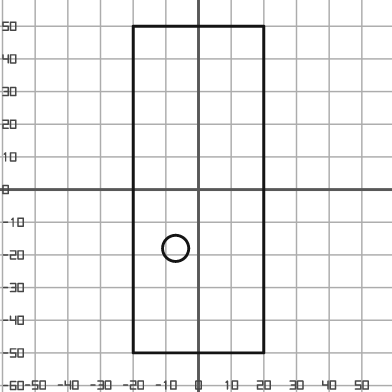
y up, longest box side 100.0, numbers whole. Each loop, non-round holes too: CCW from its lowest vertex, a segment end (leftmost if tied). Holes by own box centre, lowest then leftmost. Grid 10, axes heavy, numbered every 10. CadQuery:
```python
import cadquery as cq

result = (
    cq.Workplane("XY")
    .moveTo(-20.0, -50.0)
    .lineTo(20.0, -50.0)
    .lineTo(20.0, 50.0)
    .lineTo(-20.0, 50.0)
    .close()
    .moveTo(-7.0, -18.0)
    .circle(4.0)
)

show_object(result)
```